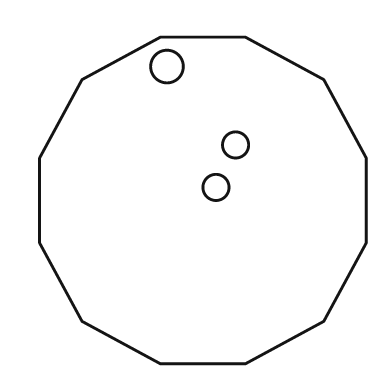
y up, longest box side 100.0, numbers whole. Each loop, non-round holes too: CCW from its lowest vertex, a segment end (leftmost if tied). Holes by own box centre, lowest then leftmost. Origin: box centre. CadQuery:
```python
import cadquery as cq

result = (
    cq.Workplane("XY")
    .moveTo(-13.0, -50.0)
    .lineTo(13.0, -50.0)
    .lineTo(37.0, -37.0)
    .lineTo(50.0, -13.0)
    .lineTo(50.0, 13.0)
    .lineTo(37.0, 37.0)
    .lineTo(13.0, 50.0)
    .lineTo(-13.0, 50.0)
    .lineTo(-37.0, 37.0)
    .lineTo(-50.0, 13.0)
    .lineTo(-50.0, -13.0)
    .lineTo(-37.0, -37.0)
    .close()
    .moveTo(4.0, 4.0)
    .circle(4.0)
    .moveTo(10.0, 17.0)
    .circle(4.0)
    .moveTo(-11.0, 41.0)
    .circle(5.0)
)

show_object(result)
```